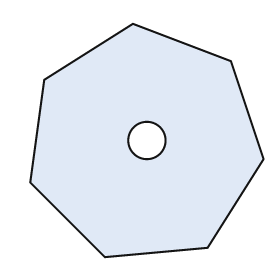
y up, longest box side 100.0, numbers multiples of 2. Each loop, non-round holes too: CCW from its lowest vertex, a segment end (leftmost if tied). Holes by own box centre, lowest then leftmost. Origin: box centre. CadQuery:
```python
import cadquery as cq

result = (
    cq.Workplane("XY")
    .moveTo(-18.0, -50.0)
    .lineTo(26.0, -46.0)
    .lineTo(50.0, -8.0)
    .lineTo(36.0, 34.0)
    .lineTo(-6.0, 50.0)
    .lineTo(-44.0, 26.0)
    .lineTo(-50.0, -18.0)
    .close()
    .moveTo(0.0, 0.0)
    .circle(8.0)
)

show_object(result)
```